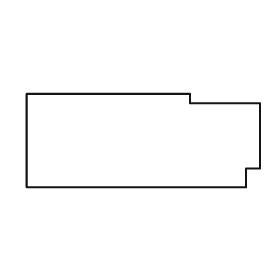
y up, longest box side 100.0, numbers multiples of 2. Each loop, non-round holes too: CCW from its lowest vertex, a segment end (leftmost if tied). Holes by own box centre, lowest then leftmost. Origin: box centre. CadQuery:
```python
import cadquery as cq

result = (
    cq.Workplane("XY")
    .moveTo(-50.0, -20.0)
    .lineTo(44.0, -20.0)
    .lineTo(44.0, -12.0)
    .lineTo(50.0, -12.0)
    .lineTo(50.0, 16.0)
    .lineTo(20.0, 16.0)
    .lineTo(20.0, 20.0)
    .lineTo(-50.0, 20.0)
    .close()
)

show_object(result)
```